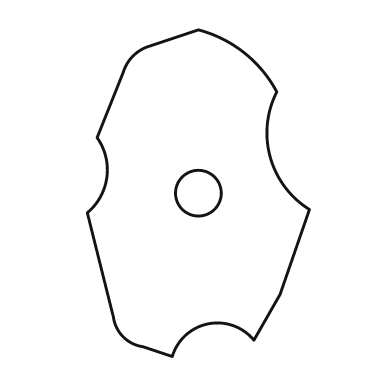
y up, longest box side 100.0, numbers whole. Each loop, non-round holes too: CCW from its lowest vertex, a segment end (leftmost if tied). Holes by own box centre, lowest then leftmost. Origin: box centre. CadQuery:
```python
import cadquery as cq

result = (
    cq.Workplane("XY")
    .moveTo(-8.0, -50.0)
    .threePointArc((3.0, -40.0), (17.0, -45.0))
    .lineTo(25.0, -31.0)
    .lineTo(34.0, -5.0)
    .threePointArc((22.0, 11.0), (24.0, 31.0))
    .threePointArc((14.0, 43.0), (0.0, 50.0))
    .lineTo(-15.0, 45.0)
    .threePointArc((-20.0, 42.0), (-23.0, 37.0))
    .lineTo(-31.0, 17.0)
    .threePointArc((-28.0, 5.0), (-34.0, -6.0))
    .lineTo(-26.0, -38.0)
    .threePointArc((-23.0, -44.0), (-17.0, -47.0))
    .close()
    .moveTo(0.0, 0.0)
    .circle(7.0)
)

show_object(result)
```